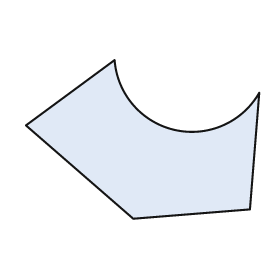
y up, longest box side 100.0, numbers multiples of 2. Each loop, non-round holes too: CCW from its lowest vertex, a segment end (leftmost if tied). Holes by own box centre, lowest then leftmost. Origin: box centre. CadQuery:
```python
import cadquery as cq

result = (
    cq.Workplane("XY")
    .moveTo(-4.0, -34.0)
    .lineTo(46.0, -30.0)
    .lineTo(50.0, 20.0)
    .threePointArc((14.0, 4.0), (-12.0, 34.0))
    .lineTo(-50.0, 6.0)
    .close()
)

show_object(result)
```